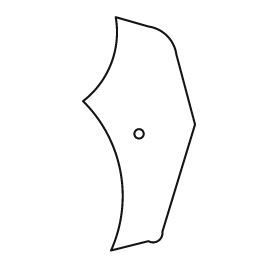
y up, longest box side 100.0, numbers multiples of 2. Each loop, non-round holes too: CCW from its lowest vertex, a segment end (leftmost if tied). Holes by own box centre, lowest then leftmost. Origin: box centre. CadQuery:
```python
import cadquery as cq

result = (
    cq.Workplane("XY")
    .moveTo(-12.0, -50.0)
    .lineTo(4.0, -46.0)
    .threePointArc((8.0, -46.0), (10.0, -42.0))
    .lineTo(24.0, 4.0)
    .lineTo(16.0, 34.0)
    .threePointArc((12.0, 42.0), (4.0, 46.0))
    .lineTo(-10.0, 50.0)
    .threePointArc((-12.0, 30.0), (-24.0, 14.0))
    .threePointArc((-8.0, -16.0), (-12.0, -50.0))
    .close()
    .moveTo(0.0, 0.0)
    .circle(2.0)
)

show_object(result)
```